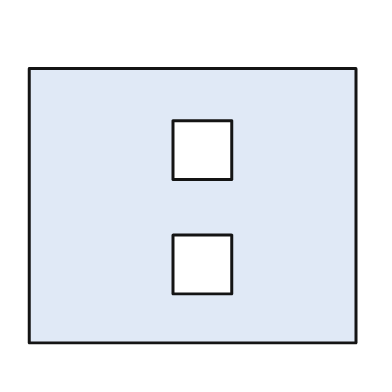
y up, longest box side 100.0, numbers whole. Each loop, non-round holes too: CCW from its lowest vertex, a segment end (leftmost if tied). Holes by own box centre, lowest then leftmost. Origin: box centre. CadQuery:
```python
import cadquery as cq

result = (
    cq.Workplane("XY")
    .moveTo(-50.0, -42.0)
    .lineTo(50.0, -42.0)
    .lineTo(50.0, 42.0)
    .lineTo(-50.0, 42.0)
    .close()
    .moveTo(-6.0, -27.0)
    .lineTo(12.0, -27.0)
    .lineTo(12.0, -9.0)
    .lineTo(-6.0, -9.0)
    .close()
    .moveTo(-6.0, 8.0)
    .lineTo(12.0, 8.0)
    .lineTo(12.0, 26.0)
    .lineTo(-6.0, 26.0)
    .close()
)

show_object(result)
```